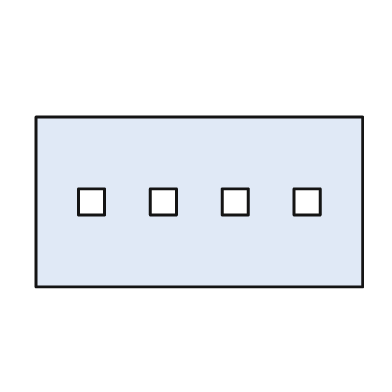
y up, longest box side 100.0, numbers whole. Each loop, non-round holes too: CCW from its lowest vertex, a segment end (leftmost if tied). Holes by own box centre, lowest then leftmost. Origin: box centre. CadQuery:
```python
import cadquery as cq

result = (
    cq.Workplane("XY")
    .moveTo(-50.0, -26.0)
    .lineTo(50.0, -26.0)
    .lineTo(50.0, 26.0)
    .lineTo(-50.0, 26.0)
    .close()
    .moveTo(-37.0, -4.0)
    .lineTo(-29.0, -4.0)
    .lineTo(-29.0, 4.0)
    .lineTo(-37.0, 4.0)
    .close()
    .moveTo(-15.0, -4.0)
    .lineTo(-7.0, -4.0)
    .lineTo(-7.0, 4.0)
    .lineTo(-15.0, 4.0)
    .close()
    .moveTo(7.0, -4.0)
    .lineTo(15.0, -4.0)
    .lineTo(15.0, 4.0)
    .lineTo(7.0, 4.0)
    .close()
    .moveTo(29.0, -4.0)
    .lineTo(37.0, -4.0)
    .lineTo(37.0, 4.0)
    .lineTo(29.0, 4.0)
    .close()
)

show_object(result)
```